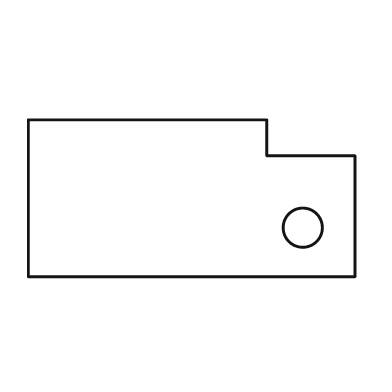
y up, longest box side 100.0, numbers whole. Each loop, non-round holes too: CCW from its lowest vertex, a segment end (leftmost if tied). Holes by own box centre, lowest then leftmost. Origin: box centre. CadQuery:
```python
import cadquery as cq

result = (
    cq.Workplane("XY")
    .moveTo(-50.0, -24.0)
    .lineTo(50.0, -24.0)
    .lineTo(50.0, 13.0)
    .lineTo(23.0, 13.0)
    .lineTo(23.0, 24.0)
    .lineTo(-50.0, 24.0)
    .close()
    .moveTo(34.0, -9.0)
    .circle(6.0)
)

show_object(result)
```